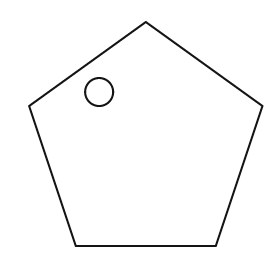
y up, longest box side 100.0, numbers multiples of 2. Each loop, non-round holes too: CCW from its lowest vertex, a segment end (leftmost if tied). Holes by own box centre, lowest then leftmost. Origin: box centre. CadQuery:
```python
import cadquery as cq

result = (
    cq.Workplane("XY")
    .moveTo(-30.0, -48.0)
    .lineTo(30.0, -48.0)
    .lineTo(50.0, 12.0)
    .lineTo(0.0, 48.0)
    .lineTo(-50.0, 12.0)
    .close()
    .moveTo(-20.0, 18.0)
    .circle(6.0)
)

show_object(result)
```